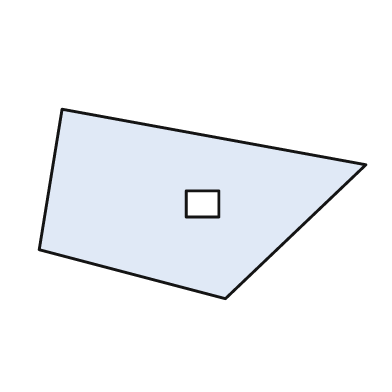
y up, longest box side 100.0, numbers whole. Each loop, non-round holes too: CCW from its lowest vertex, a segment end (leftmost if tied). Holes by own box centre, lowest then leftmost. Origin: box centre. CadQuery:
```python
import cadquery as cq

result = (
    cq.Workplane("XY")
    .moveTo(7.0, -29.0)
    .lineTo(50.0, 12.0)
    .lineTo(-43.0, 29.0)
    .lineTo(-50.0, -14.0)
    .close()
    .moveTo(-5.0, -4.0)
    .lineTo(5.0, -4.0)
    .lineTo(5.0, 4.0)
    .lineTo(-5.0, 4.0)
    .close()
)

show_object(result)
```